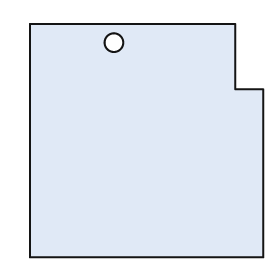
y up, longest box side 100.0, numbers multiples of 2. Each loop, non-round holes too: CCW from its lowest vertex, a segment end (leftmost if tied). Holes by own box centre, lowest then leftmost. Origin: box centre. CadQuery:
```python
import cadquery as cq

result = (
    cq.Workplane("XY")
    .moveTo(-50.0, -50.0)
    .lineTo(50.0, -50.0)
    .lineTo(50.0, 22.0)
    .lineTo(38.0, 22.0)
    .lineTo(38.0, 50.0)
    .lineTo(-50.0, 50.0)
    .close()
    .moveTo(-14.0, 42.0)
    .circle(4.0)
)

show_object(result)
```